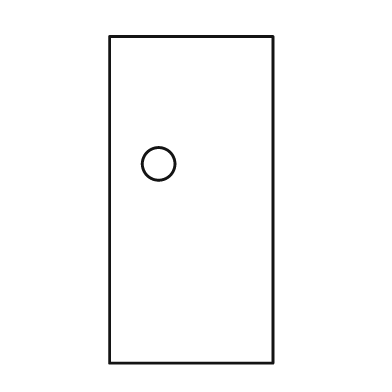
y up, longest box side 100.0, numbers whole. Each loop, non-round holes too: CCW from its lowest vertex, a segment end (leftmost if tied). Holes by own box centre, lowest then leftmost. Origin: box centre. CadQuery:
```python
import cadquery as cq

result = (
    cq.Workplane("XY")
    .moveTo(-25.0, -50.0)
    .lineTo(25.0, -50.0)
    .lineTo(25.0, 50.0)
    .lineTo(-25.0, 50.0)
    .close()
    .moveTo(-10.0, 11.0)
    .circle(5.0)
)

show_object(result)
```